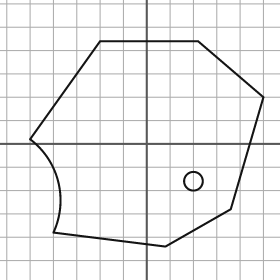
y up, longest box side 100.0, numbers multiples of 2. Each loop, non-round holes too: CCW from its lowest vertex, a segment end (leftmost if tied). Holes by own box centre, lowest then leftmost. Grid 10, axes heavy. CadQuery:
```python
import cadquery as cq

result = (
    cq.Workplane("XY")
    .moveTo(8.0, -44.0)
    .lineTo(36.0, -28.0)
    .lineTo(50.0, 20.0)
    .lineTo(22.0, 44.0)
    .lineTo(-20.0, 44.0)
    .lineTo(-50.0, 2.0)
    .threePointArc((-38.0, -16.0), (-40.0, -38.0))
    .close()
    .moveTo(20.0, -16.0)
    .circle(4.0)
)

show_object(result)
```